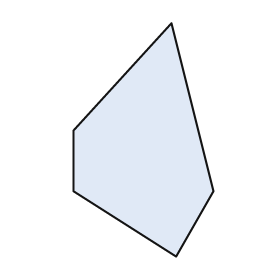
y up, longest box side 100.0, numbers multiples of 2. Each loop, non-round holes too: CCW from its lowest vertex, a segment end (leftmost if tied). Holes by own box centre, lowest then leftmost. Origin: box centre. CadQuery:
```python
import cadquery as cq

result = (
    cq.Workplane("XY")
    .moveTo(14.0, -50.0)
    .lineTo(30.0, -22.0)
    .lineTo(12.0, 50.0)
    .lineTo(-30.0, 4.0)
    .lineTo(-30.0, -22.0)
    .close()
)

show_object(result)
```